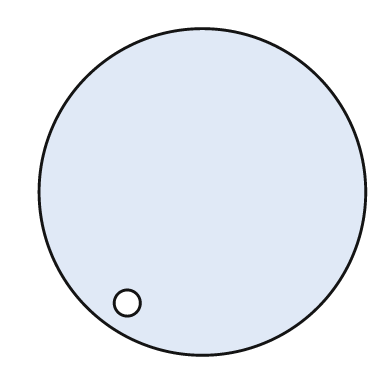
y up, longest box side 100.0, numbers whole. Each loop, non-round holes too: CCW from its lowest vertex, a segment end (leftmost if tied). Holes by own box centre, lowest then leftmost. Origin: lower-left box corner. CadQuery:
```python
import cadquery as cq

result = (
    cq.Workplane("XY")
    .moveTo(50.0, 50.0)
    .circle(50.0)
    .moveTo(27.0, 16.0)
    .circle(4.0)
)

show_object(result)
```